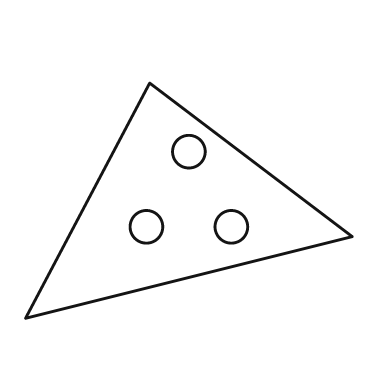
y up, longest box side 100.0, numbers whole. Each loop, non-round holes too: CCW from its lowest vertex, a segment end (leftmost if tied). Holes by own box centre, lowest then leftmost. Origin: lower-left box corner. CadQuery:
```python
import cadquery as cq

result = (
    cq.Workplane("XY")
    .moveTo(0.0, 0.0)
    .lineTo(100.0, 25.0)
    .lineTo(38.0, 72.0)
    .close()
    .moveTo(37.0, 28.0)
    .circle(5.0)
    .moveTo(63.0, 28.0)
    .circle(5.0)
    .moveTo(50.0, 51.0)
    .circle(5.0)
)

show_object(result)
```